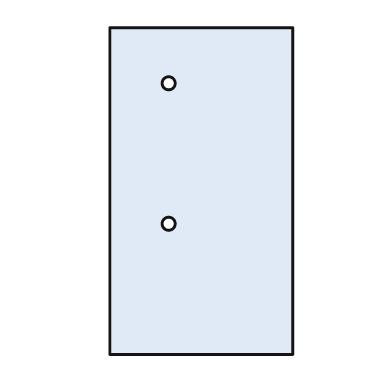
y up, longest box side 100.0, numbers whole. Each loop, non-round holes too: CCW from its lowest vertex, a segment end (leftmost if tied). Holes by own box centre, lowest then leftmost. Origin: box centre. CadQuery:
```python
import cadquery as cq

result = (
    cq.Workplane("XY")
    .moveTo(-28.0, -50.0)
    .lineTo(28.0, -50.0)
    .lineTo(28.0, 50.0)
    .lineTo(-28.0, 50.0)
    .close()
    .moveTo(-10.0, -10.0)
    .circle(2.0)
    .moveTo(-10.0, 33.0)
    .circle(2.0)
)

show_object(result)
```